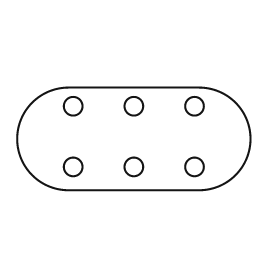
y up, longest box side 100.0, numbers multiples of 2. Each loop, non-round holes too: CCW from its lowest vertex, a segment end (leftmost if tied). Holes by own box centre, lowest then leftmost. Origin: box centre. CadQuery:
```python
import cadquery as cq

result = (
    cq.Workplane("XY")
    .moveTo(-28.0, -22.0)
    .lineTo(28.0, -22.0)
    .threePointArc((50.0, 0.0), (28.0, 22.0))
    .lineTo(-28.0, 22.0)
    .threePointArc((-50.0, 0.0), (-28.0, -22.0))
    .close()
    .moveTo(-26.0, -12.0)
    .circle(4.0)
    .moveTo(0.0, -12.0)
    .circle(4.0)
    .moveTo(26.0, -12.0)
    .circle(4.0)
    .moveTo(-26.0, 14.0)
    .circle(4.0)
    .moveTo(0.0, 14.0)
    .circle(4.0)
    .moveTo(26.0, 14.0)
    .circle(4.0)
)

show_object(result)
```